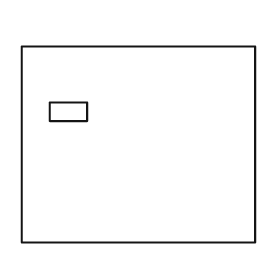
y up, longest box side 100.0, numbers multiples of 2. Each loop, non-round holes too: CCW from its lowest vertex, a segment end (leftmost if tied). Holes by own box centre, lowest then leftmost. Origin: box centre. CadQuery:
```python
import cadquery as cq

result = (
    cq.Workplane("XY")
    .moveTo(-50.0, -42.0)
    .lineTo(50.0, -42.0)
    .lineTo(50.0, 42.0)
    .lineTo(-50.0, 42.0)
    .close()
    .moveTo(-38.0, 10.0)
    .lineTo(-22.0, 10.0)
    .lineTo(-22.0, 18.0)
    .lineTo(-38.0, 18.0)
    .close()
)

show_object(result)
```